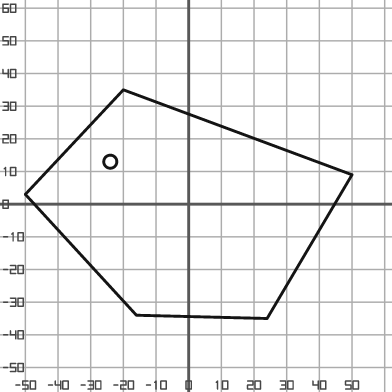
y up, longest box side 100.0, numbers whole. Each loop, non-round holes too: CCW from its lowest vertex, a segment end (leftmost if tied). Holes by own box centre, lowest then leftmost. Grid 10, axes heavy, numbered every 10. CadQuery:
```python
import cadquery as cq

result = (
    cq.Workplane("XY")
    .moveTo(24.0, -35.0)
    .lineTo(50.0, 9.0)
    .lineTo(-20.0, 35.0)
    .lineTo(-50.0, 3.0)
    .lineTo(-16.0, -34.0)
    .close()
    .moveTo(-24.0, 13.0)
    .circle(2.0)
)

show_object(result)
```